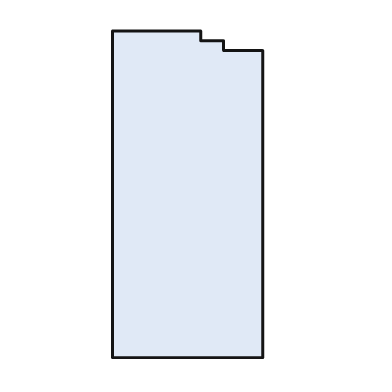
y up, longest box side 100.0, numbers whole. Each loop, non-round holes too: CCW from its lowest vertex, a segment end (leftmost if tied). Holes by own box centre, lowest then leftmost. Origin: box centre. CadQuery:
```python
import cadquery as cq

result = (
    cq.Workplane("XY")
    .moveTo(-23.0, -50.0)
    .lineTo(23.0, -50.0)
    .lineTo(23.0, 44.0)
    .lineTo(11.0, 44.0)
    .lineTo(11.0, 47.0)
    .lineTo(4.0, 47.0)
    .lineTo(4.0, 50.0)
    .lineTo(-23.0, 50.0)
    .close()
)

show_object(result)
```